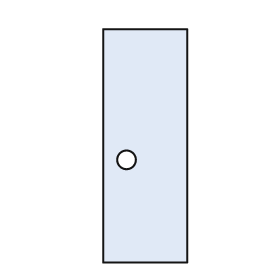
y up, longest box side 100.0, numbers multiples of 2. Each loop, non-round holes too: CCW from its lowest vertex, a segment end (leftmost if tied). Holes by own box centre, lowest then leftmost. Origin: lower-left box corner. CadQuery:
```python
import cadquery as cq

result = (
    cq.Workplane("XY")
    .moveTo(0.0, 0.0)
    .lineTo(36.0, 0.0)
    .lineTo(36.0, 100.0)
    .lineTo(0.0, 100.0)
    .close()
    .moveTo(10.0, 44.0)
    .circle(4.0)
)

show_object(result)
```